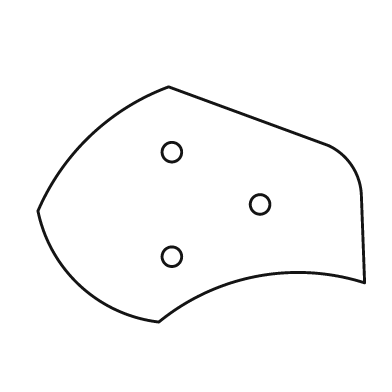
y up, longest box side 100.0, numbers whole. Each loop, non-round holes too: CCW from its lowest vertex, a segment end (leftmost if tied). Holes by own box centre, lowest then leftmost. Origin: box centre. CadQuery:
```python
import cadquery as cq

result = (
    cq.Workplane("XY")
    .moveTo(-13.0, -36.0)
    .threePointArc((17.0, -22.0), (50.0, -24.0))
    .lineTo(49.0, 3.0)
    .threePointArc((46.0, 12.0), (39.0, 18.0))
    .lineTo(-10.0, 36.0)
    .threePointArc((-34.0, 21.0), (-50.0, -2.0))
    .threePointArc((-37.0, -25.0), (-13.0, -36.0))
    .close()
    .moveTo(-9.0, -16.0)
    .circle(3.0)
    .moveTo(18.0, 0.0)
    .circle(3.0)
    .moveTo(-9.0, 16.0)
    .circle(3.0)
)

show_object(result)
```